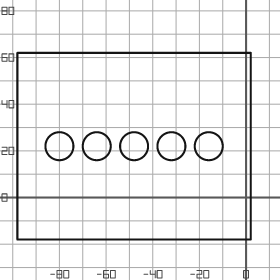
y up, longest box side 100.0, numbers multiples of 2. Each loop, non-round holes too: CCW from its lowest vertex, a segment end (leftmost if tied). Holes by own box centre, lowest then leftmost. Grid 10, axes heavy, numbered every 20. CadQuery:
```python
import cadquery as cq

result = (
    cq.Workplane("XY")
    .moveTo(-98.0, -18.0)
    .lineTo(2.0, -18.0)
    .lineTo(2.0, 62.0)
    .lineTo(-98.0, 62.0)
    .close()
    .moveTo(-80.0, 22.0)
    .circle(6.0)
    .moveTo(-64.0, 22.0)
    .circle(6.0)
    .moveTo(-48.0, 22.0)
    .circle(6.0)
    .moveTo(-32.0, 22.0)
    .circle(6.0)
    .moveTo(-16.0, 22.0)
    .circle(6.0)
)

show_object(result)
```